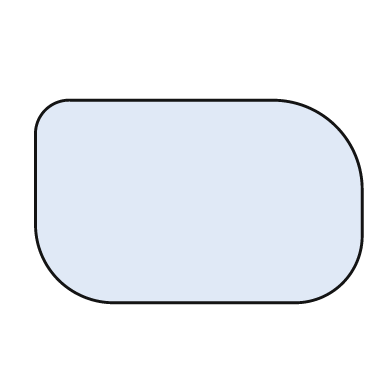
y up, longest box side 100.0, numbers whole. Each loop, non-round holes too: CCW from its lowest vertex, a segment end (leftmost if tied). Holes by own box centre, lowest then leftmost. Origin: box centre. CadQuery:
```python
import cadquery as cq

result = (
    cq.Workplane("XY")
    .moveTo(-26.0, -31.0)
    .lineTo(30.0, -31.0)
    .threePointArc((44.0, -25.0), (50.0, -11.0))
    .lineTo(50.0, 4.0)
    .threePointArc((42.0, 23.0), (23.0, 31.0))
    .lineTo(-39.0, 31.0)
    .threePointArc((-47.0, 28.0), (-50.0, 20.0))
    .lineTo(-50.0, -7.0)
    .threePointArc((-43.0, -24.0), (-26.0, -31.0))
    .close()
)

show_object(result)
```